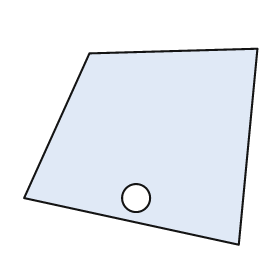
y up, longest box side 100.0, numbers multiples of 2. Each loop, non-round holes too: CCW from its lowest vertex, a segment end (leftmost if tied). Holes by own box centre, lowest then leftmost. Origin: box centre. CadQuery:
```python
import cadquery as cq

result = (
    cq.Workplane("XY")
    .moveTo(42.0, -42.0)
    .lineTo(50.0, 42.0)
    .lineTo(-22.0, 40.0)
    .lineTo(-50.0, -22.0)
    .close()
    .moveTo(-2.0, -22.0)
    .circle(6.0)
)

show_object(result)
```